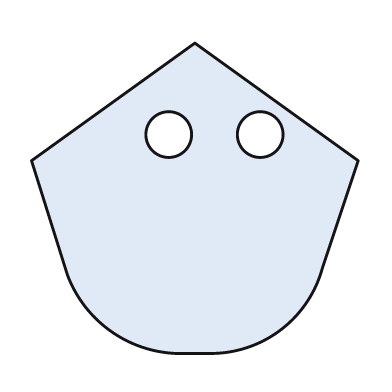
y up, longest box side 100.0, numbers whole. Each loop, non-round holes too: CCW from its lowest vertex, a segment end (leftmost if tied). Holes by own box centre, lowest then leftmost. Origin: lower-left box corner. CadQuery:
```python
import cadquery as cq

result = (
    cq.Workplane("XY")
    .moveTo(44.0, 0.0)
    .lineTo(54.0, 0.0)
    .threePointArc((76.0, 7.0), (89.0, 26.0))
    .lineTo(100.0, 59.0)
    .lineTo(50.0, 95.0)
    .lineTo(0.0, 59.0)
    .lineTo(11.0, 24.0)
    .threePointArc((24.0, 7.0), (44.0, 0.0))
    .close()
    .moveTo(42.0, 67.0)
    .circle(7.0)
    .moveTo(70.0, 67.0)
    .circle(7.0)
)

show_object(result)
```